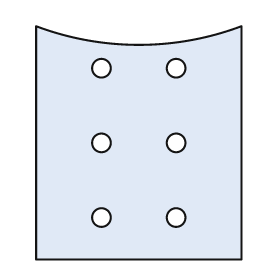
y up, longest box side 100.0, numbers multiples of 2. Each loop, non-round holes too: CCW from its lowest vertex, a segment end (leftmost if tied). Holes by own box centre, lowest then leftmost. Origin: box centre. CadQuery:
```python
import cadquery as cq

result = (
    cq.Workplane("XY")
    .moveTo(-44.0, -50.0)
    .lineTo(44.0, -50.0)
    .lineTo(44.0, 50.0)
    .threePointArc((0.0, 42.0), (-44.0, 50.0))
    .close()
    .moveTo(-16.0, -32.0)
    .circle(4.0)
    .moveTo(16.0, -32.0)
    .circle(4.0)
    .moveTo(-16.0, 0.0)
    .circle(4.0)
    .moveTo(16.0, 0.0)
    .circle(4.0)
    .moveTo(-16.0, 32.0)
    .circle(4.0)
    .moveTo(16.0, 32.0)
    .circle(4.0)
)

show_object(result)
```